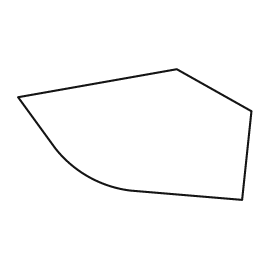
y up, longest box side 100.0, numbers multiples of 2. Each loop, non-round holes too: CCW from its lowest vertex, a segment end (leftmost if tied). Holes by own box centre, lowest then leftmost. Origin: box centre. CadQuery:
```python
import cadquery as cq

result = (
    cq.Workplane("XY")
    .moveTo(46.0, -28.0)
    .lineTo(50.0, 10.0)
    .lineTo(18.0, 28.0)
    .lineTo(-50.0, 16.0)
    .lineTo(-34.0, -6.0)
    .threePointArc((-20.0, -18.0), (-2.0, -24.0))
    .close()
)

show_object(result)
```